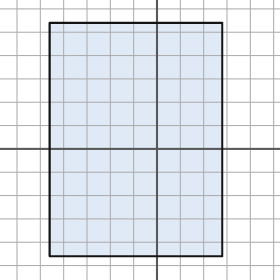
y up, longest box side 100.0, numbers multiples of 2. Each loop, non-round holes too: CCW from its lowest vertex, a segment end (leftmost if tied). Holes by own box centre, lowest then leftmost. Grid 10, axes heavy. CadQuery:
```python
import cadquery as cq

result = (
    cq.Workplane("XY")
    .moveTo(-46.0, -46.0)
    .lineTo(28.0, -46.0)
    .lineTo(28.0, 54.0)
    .lineTo(-46.0, 54.0)
    .close()
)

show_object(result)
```